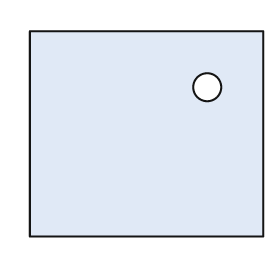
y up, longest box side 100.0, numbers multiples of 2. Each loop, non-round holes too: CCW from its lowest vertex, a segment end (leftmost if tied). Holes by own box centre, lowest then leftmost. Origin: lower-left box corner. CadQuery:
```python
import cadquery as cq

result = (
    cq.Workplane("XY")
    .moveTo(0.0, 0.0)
    .lineTo(100.0, 0.0)
    .lineTo(100.0, 88.0)
    .lineTo(0.0, 88.0)
    .close()
    .moveTo(76.0, 64.0)
    .circle(6.0)
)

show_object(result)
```